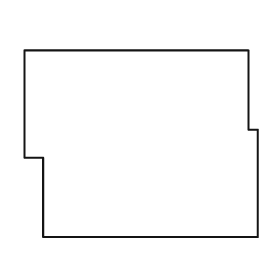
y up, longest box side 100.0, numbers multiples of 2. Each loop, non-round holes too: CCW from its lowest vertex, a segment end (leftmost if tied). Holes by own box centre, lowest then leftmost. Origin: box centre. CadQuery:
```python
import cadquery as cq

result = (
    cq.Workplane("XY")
    .moveTo(-42.0, -40.0)
    .lineTo(50.0, -40.0)
    .lineTo(50.0, 6.0)
    .lineTo(46.0, 6.0)
    .lineTo(46.0, 40.0)
    .lineTo(-50.0, 40.0)
    .lineTo(-50.0, -6.0)
    .lineTo(-42.0, -6.0)
    .close()
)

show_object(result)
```